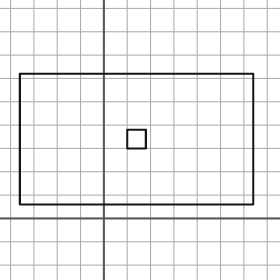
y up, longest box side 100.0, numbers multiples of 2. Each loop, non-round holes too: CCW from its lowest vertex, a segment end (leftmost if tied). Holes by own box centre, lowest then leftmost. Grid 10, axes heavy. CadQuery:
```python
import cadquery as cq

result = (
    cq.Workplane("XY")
    .moveTo(-36.0, 6.0)
    .lineTo(64.0, 6.0)
    .lineTo(64.0, 62.0)
    .lineTo(-36.0, 62.0)
    .close()
    .moveTo(10.0, 30.0)
    .lineTo(18.0, 30.0)
    .lineTo(18.0, 38.0)
    .lineTo(10.0, 38.0)
    .close()
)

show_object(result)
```